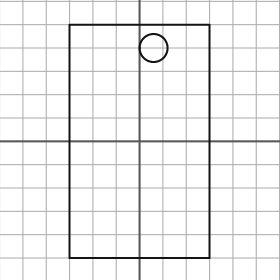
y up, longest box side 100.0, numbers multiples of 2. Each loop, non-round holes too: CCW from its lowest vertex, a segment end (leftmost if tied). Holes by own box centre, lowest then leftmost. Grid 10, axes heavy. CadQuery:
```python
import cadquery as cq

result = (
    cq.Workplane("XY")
    .moveTo(-30.0, -50.0)
    .lineTo(30.0, -50.0)
    .lineTo(30.0, 50.0)
    .lineTo(-30.0, 50.0)
    .close()
    .moveTo(6.0, 40.0)
    .circle(6.0)
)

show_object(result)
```